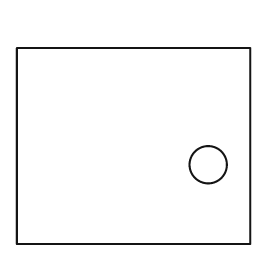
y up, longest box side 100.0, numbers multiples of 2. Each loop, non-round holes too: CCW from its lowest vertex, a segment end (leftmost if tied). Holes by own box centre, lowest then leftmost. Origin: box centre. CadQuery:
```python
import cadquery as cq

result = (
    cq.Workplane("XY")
    .moveTo(-50.0, -42.0)
    .lineTo(50.0, -42.0)
    .lineTo(50.0, 42.0)
    .lineTo(-50.0, 42.0)
    .close()
    .moveTo(32.0, -8.0)
    .circle(8.0)
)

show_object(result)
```